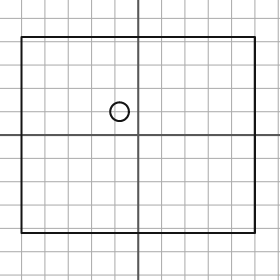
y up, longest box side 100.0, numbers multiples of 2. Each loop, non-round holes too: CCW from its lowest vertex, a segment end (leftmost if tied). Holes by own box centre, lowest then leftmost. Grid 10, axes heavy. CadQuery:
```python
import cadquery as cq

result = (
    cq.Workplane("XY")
    .moveTo(-50.0, -42.0)
    .lineTo(50.0, -42.0)
    .lineTo(50.0, 42.0)
    .lineTo(-50.0, 42.0)
    .close()
    .moveTo(-8.0, 10.0)
    .circle(4.0)
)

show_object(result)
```